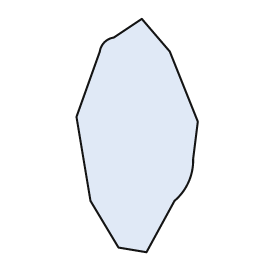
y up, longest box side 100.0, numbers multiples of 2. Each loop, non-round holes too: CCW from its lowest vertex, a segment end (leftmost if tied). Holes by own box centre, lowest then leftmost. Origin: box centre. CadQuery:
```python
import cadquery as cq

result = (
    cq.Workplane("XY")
    .moveTo(4.0, -50.0)
    .lineTo(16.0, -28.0)
    .threePointArc((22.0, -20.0), (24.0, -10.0))
    .lineTo(26.0, 6.0)
    .lineTo(14.0, 36.0)
    .lineTo(2.0, 50.0)
    .lineTo(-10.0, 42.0)
    .threePointArc((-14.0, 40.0), (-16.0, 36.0))
    .lineTo(-26.0, 8.0)
    .lineTo(-20.0, -28.0)
    .lineTo(-8.0, -48.0)
    .close()
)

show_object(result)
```